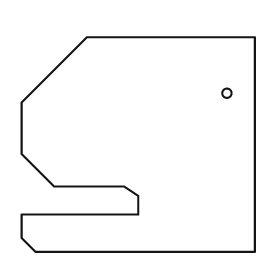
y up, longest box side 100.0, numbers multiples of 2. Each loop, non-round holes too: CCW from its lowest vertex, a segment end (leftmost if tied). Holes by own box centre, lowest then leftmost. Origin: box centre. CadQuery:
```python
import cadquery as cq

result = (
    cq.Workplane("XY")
    .moveTo(-44.0, -46.0)
    .lineTo(50.0, -46.0)
    .lineTo(50.0, 46.0)
    .lineTo(-22.0, 46.0)
    .lineTo(-50.0, 18.0)
    .lineTo(-50.0, -4.0)
    .lineTo(-36.0, -18.0)
    .lineTo(-6.0, -18.0)
    .lineTo(0.0, -22.0)
    .lineTo(0.0, -30.0)
    .lineTo(-50.0, -30.0)
    .lineTo(-50.0, -40.0)
    .close()
    .moveTo(38.0, 22.0)
    .circle(2.0)
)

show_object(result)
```